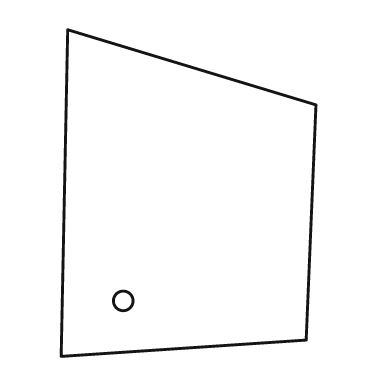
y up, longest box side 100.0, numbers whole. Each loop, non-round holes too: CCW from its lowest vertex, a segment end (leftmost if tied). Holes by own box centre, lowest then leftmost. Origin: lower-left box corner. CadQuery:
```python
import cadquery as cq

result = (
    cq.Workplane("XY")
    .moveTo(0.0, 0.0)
    .lineTo(75.0, 5.0)
    .lineTo(78.0, 77.0)
    .lineTo(2.0, 100.0)
    .close()
    .moveTo(19.0, 17.0)
    .circle(3.0)
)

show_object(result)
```